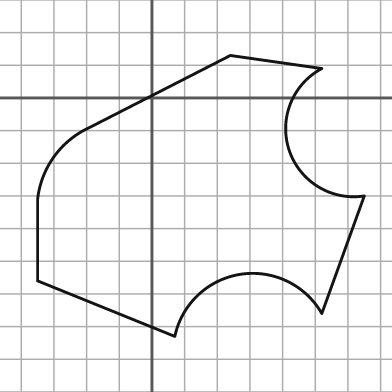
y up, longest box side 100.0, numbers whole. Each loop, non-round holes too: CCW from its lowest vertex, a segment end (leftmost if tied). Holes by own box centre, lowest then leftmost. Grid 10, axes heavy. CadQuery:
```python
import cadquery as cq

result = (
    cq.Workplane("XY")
    .moveTo(7.0, -73.0)
    .threePointArc((27.0, -54.0), (52.0, -66.0))
    .lineTo(65.0, -30.0)
    .threePointArc((42.0, -16.0), (52.0, 9.0))
    .lineTo(24.0, 13.0)
    .lineTo(-19.0, -9.0)
    .threePointArc((-30.0, -18.0), (-35.0, -31.0))
    .lineTo(-35.0, -56.0)
    .close()
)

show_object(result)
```